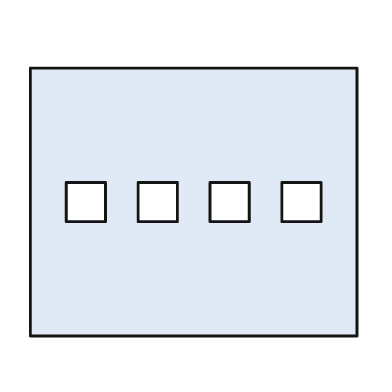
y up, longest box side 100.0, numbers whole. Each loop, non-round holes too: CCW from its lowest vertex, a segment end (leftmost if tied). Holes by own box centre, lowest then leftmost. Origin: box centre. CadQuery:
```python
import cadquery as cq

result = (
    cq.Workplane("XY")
    .moveTo(-50.0, -41.0)
    .lineTo(50.0, -41.0)
    .lineTo(50.0, 41.0)
    .lineTo(-50.0, 41.0)
    .close()
    .moveTo(-39.0, -6.0)
    .lineTo(-27.0, -6.0)
    .lineTo(-27.0, 6.0)
    .lineTo(-39.0, 6.0)
    .close()
    .moveTo(-17.0, -6.0)
    .lineTo(-5.0, -6.0)
    .lineTo(-5.0, 6.0)
    .lineTo(-17.0, 6.0)
    .close()
    .moveTo(5.0, -6.0)
    .lineTo(17.0, -6.0)
    .lineTo(17.0, 6.0)
    .lineTo(5.0, 6.0)
    .close()
    .moveTo(27.0, -6.0)
    .lineTo(39.0, -6.0)
    .lineTo(39.0, 6.0)
    .lineTo(27.0, 6.0)
    .close()
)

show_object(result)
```